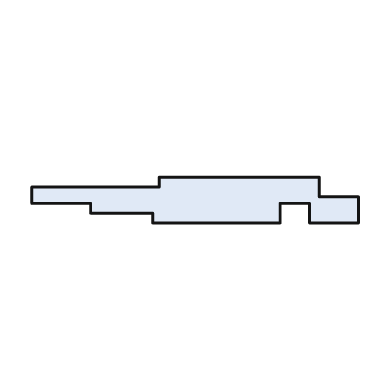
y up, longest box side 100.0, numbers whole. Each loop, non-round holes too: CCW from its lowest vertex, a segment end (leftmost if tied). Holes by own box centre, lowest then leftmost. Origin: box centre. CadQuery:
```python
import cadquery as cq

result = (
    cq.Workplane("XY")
    .moveTo(-13.0, -7.0)
    .lineTo(26.0, -7.0)
    .lineTo(26.0, -1.0)
    .lineTo(35.0, -1.0)
    .lineTo(35.0, -7.0)
    .lineTo(50.0, -7.0)
    .lineTo(50.0, 1.0)
    .lineTo(38.0, 1.0)
    .lineTo(38.0, 7.0)
    .lineTo(-11.0, 7.0)
    .lineTo(-11.0, 4.0)
    .lineTo(-50.0, 4.0)
    .lineTo(-50.0, -1.0)
    .lineTo(-32.0, -1.0)
    .lineTo(-32.0, -4.0)
    .lineTo(-13.0, -4.0)
    .close()
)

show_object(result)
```